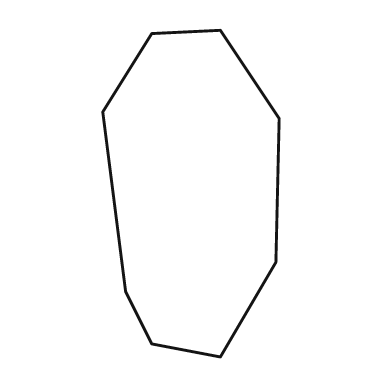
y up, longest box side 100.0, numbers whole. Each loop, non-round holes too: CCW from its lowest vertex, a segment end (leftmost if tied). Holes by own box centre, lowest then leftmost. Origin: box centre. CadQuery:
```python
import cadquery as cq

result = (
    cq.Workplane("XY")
    .moveTo(9.0, -50.0)
    .lineTo(26.0, -21.0)
    .lineTo(27.0, 23.0)
    .lineTo(9.0, 50.0)
    .lineTo(-12.0, 49.0)
    .lineTo(-27.0, 25.0)
    .lineTo(-20.0, -30.0)
    .lineTo(-12.0, -46.0)
    .close()
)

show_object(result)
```